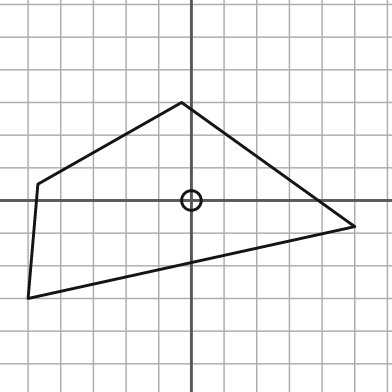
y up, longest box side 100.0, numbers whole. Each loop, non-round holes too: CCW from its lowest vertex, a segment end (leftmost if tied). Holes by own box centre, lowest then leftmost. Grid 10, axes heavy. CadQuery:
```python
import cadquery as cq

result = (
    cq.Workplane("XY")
    .moveTo(-50.0, -30.0)
    .lineTo(50.0, -8.0)
    .lineTo(-3.0, 30.0)
    .lineTo(-47.0, 5.0)
    .close()
    .moveTo(0.0, 0.0)
    .circle(3.0)
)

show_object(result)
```